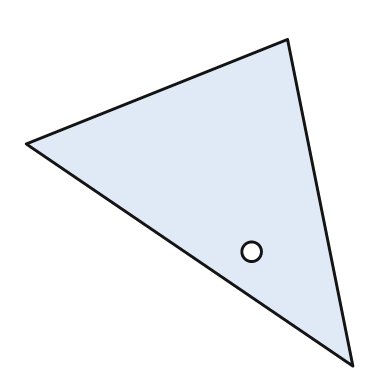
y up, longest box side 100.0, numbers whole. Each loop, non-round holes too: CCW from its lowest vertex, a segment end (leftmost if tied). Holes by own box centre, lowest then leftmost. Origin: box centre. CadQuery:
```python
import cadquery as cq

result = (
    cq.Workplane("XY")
    .moveTo(50.0, -50.0)
    .lineTo(30.0, 50.0)
    .lineTo(-50.0, 18.0)
    .close()
    .moveTo(19.0, -15.0)
    .circle(3.0)
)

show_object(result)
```